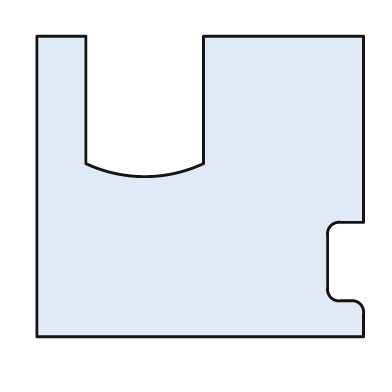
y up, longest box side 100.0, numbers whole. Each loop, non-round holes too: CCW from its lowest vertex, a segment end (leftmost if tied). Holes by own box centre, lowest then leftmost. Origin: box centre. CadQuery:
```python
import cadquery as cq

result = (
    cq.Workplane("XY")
    .moveTo(-50.0, -46.0)
    .lineTo(50.0, -46.0)
    .lineTo(50.0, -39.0)
    .threePointArc((49.0, -36.0), (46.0, -35.0))
    .lineTo(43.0, -35.0)
    .threePointArc((40.0, -34.0), (39.0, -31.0))
    .lineTo(39.0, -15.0)
    .threePointArc((40.0, -12.0), (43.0, -11.0))
    .lineTo(50.0, -11.0)
    .lineTo(50.0, 46.0)
    .lineTo(1.0, 46.0)
    .lineTo(1.0, 7.0)
    .threePointArc((-17.0, 3.0), (-35.0, 7.0))
    .lineTo(-35.0, 46.0)
    .lineTo(-50.0, 46.0)
    .close()
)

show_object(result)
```